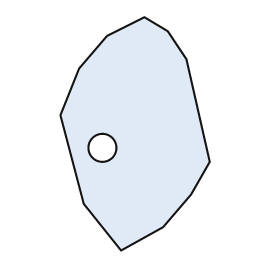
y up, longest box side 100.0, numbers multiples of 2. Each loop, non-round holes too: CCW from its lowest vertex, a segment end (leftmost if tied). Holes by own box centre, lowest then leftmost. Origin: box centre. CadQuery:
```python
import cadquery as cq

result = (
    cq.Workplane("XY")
    .moveTo(-6.0, -50.0)
    .lineTo(12.0, -40.0)
    .lineTo(24.0, -26.0)
    .lineTo(32.0, -12.0)
    .lineTo(22.0, 32.0)
    .lineTo(14.0, 44.0)
    .lineTo(4.0, 50.0)
    .lineTo(-12.0, 42.0)
    .lineTo(-24.0, 28.0)
    .lineTo(-32.0, 8.0)
    .lineTo(-22.0, -30.0)
    .close()
    .moveTo(-14.0, -6.0)
    .circle(6.0)
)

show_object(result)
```